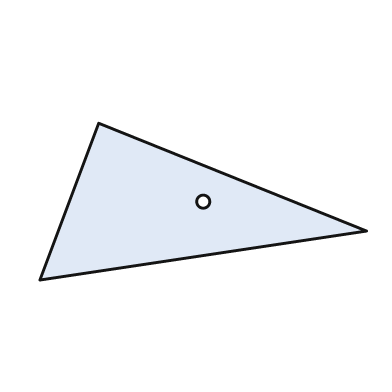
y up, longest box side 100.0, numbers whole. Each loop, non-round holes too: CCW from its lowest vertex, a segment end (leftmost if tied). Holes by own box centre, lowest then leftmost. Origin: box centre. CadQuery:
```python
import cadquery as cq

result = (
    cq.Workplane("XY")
    .moveTo(-50.0, -24.0)
    .lineTo(50.0, -9.0)
    .lineTo(-32.0, 24.0)
    .close()
    .moveTo(0.0, 0.0)
    .circle(2.0)
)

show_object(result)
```